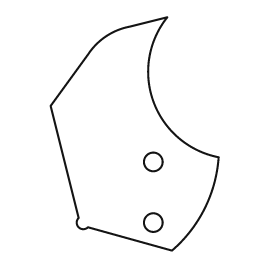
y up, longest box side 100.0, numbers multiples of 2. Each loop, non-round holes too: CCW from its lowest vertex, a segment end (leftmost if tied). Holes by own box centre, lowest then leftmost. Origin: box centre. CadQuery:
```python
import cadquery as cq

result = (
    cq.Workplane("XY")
    .moveTo(16.0, -50.0)
    .threePointArc((30.0, -32.0), (36.0, -10.0))
    .threePointArc((8.0, 14.0), (14.0, 50.0))
    .lineTo(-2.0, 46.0)
    .threePointArc((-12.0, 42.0), (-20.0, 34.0))
    .lineTo(-36.0, 12.0)
    .lineTo(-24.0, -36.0)
    .threePointArc((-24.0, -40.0), (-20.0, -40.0))
    .close()
    .moveTo(8.0, -38.0)
    .circle(4.0)
    .moveTo(8.0, -12.0)
    .circle(4.0)
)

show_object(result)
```